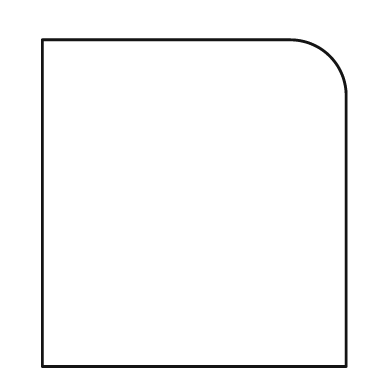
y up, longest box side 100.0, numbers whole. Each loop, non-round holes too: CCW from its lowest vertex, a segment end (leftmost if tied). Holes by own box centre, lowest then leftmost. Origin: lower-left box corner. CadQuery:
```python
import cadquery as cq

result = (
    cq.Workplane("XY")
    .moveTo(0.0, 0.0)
    .lineTo(93.0, 0.0)
    .lineTo(93.0, 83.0)
    .threePointArc((88.0, 95.0), (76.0, 100.0))
    .lineTo(0.0, 100.0)
    .close()
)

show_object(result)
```